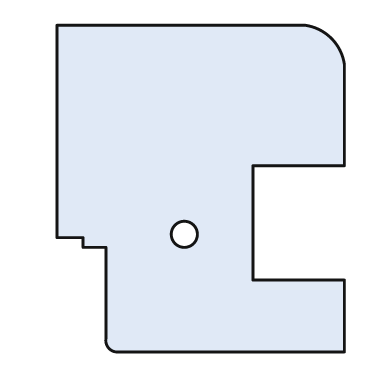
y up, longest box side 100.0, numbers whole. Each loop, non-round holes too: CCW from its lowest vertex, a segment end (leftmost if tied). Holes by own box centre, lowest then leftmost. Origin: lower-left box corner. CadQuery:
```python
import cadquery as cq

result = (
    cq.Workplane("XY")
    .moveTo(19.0, 0.0)
    .lineTo(88.0, 0.0)
    .lineTo(88.0, 22.0)
    .lineTo(60.0, 22.0)
    .lineTo(60.0, 57.0)
    .lineTo(88.0, 57.0)
    .lineTo(88.0, 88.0)
    .threePointArc((84.0, 96.0), (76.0, 100.0))
    .lineTo(0.0, 100.0)
    .lineTo(0.0, 35.0)
    .lineTo(8.0, 35.0)
    .lineTo(8.0, 32.0)
    .lineTo(15.0, 32.0)
    .lineTo(15.0, 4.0)
    .threePointArc((16.0, 1.0), (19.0, 0.0))
    .close()
    .moveTo(39.0, 36.0)
    .circle(4.0)
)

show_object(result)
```